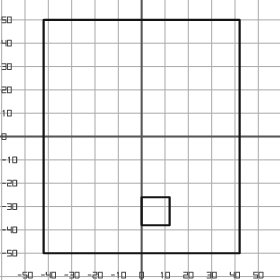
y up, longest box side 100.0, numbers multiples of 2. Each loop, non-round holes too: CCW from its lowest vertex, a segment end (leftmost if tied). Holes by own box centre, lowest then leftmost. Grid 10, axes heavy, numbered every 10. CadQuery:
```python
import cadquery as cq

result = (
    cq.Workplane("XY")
    .moveTo(-42.0, -50.0)
    .lineTo(42.0, -50.0)
    .lineTo(42.0, 50.0)
    .lineTo(-42.0, 50.0)
    .close()
    .moveTo(0.0, -38.0)
    .lineTo(12.0, -38.0)
    .lineTo(12.0, -26.0)
    .lineTo(0.0, -26.0)
    .close()
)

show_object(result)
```